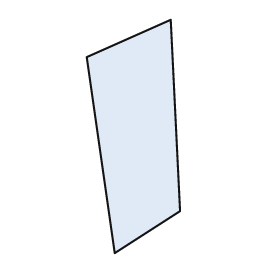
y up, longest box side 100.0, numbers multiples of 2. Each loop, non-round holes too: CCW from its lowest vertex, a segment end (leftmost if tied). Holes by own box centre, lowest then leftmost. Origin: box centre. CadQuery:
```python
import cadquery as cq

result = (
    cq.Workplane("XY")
    .moveTo(-8.0, -50.0)
    .lineTo(20.0, -32.0)
    .lineTo(16.0, 50.0)
    .lineTo(-20.0, 34.0)
    .close()
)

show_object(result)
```